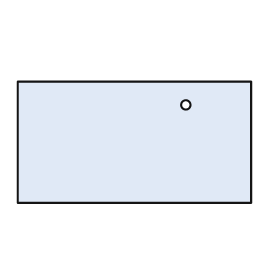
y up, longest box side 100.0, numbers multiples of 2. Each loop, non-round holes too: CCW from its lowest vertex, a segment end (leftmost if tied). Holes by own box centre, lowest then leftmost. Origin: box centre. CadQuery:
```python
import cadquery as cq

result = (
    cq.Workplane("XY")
    .moveTo(-50.0, -26.0)
    .lineTo(50.0, -26.0)
    .lineTo(50.0, 26.0)
    .lineTo(-50.0, 26.0)
    .close()
    .moveTo(22.0, 16.0)
    .circle(2.0)
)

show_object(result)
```